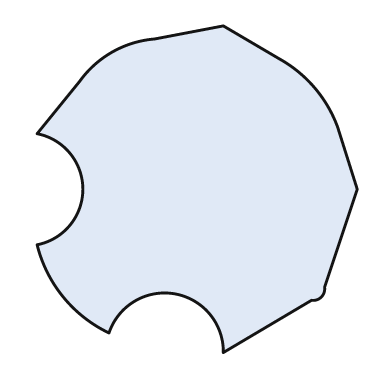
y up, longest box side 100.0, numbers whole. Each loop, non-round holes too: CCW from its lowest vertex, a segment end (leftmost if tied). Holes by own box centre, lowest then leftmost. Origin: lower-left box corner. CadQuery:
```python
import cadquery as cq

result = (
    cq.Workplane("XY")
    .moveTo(57.0, 0.0)
    .lineTo(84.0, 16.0)
    .threePointArc((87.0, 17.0), (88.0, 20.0))
    .lineTo(98.0, 50.0)
    .lineTo(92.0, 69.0)
    .threePointArc((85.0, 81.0), (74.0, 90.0))
    .lineTo(57.0, 100.0)
    .lineTo(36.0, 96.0)
    .threePointArc((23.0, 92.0), (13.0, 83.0))
    .lineTo(0.0, 67.0)
    .threePointArc((14.0, 50.0), (0.0, 33.0))
    .threePointArc((8.0, 17.0), (22.0, 6.0))
    .threePointArc((42.0, 18.0), (57.0, 0.0))
    .close()
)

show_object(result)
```